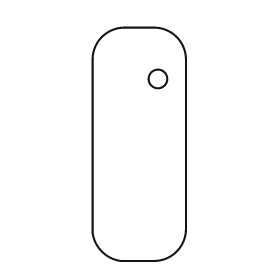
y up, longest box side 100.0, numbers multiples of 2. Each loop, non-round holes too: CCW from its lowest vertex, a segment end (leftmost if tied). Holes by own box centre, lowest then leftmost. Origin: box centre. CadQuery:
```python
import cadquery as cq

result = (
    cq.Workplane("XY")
    .moveTo(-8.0, -50.0)
    .lineTo(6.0, -50.0)
    .threePointArc((16.0, -46.0), (20.0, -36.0))
    .lineTo(20.0, 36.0)
    .threePointArc((16.0, 46.0), (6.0, 50.0))
    .lineTo(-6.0, 50.0)
    .threePointArc((-16.0, 46.0), (-20.0, 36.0))
    .lineTo(-20.0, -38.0)
    .threePointArc((-16.0, -46.0), (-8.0, -50.0))
    .close()
    .moveTo(8.0, 28.0)
    .circle(4.0)
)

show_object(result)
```